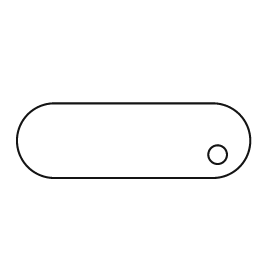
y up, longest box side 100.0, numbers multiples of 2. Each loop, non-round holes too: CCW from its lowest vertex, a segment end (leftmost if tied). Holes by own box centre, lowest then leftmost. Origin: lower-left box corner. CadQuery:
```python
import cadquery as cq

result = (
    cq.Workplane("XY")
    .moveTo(16.0, 0.0)
    .lineTo(84.0, 0.0)
    .threePointArc((100.0, 16.0), (84.0, 32.0))
    .lineTo(16.0, 32.0)
    .threePointArc((0.0, 16.0), (16.0, 0.0))
    .close()
    .moveTo(86.0, 10.0)
    .circle(4.0)
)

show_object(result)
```